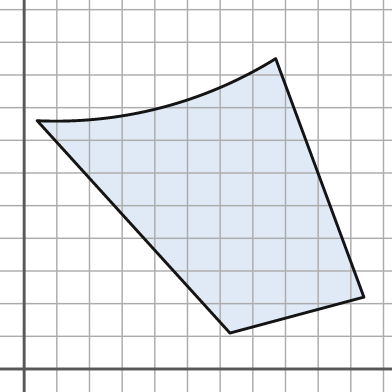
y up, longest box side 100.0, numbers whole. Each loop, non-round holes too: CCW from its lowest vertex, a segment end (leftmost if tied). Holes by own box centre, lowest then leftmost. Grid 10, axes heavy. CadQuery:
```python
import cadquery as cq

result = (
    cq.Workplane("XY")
    .moveTo(63.0, 11.0)
    .lineTo(104.0, 22.0)
    .lineTo(77.0, 95.0)
    .threePointArc((42.0, 80.0), (4.0, 76.0))
    .close()
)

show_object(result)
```